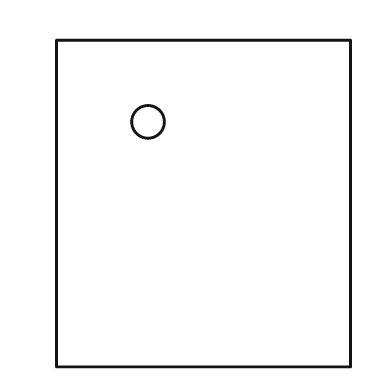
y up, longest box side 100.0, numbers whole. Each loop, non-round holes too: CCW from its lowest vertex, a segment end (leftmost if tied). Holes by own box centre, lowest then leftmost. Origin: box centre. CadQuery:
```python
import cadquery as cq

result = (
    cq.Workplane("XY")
    .moveTo(-45.0, -50.0)
    .lineTo(45.0, -50.0)
    .lineTo(45.0, 50.0)
    .lineTo(-45.0, 50.0)
    .close()
    .moveTo(-17.0, 25.0)
    .circle(5.0)
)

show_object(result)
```